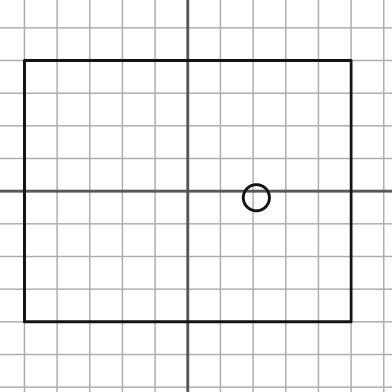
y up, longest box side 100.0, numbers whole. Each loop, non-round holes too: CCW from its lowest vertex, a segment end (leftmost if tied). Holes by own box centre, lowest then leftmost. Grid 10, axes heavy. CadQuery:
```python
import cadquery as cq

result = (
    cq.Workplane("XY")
    .moveTo(-50.0, -40.0)
    .lineTo(50.0, -40.0)
    .lineTo(50.0, 40.0)
    .lineTo(-50.0, 40.0)
    .close()
    .moveTo(21.0, -2.0)
    .circle(4.0)
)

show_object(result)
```